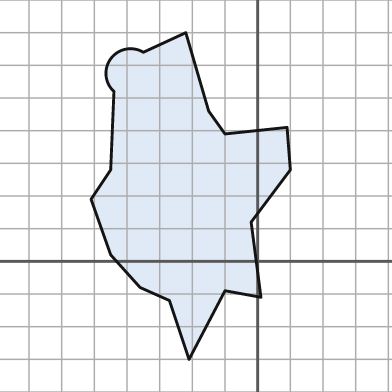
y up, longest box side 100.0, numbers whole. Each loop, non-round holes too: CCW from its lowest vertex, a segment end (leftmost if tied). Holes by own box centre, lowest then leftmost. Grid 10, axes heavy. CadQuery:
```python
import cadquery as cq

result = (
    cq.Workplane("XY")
    .moveTo(-21.0, -30.0)
    .lineTo(-10.0, -9.0)
    .lineTo(1.0, -11.0)
    .lineTo(-2.0, 12.0)
    .lineTo(10.0, 28.0)
    .lineTo(9.0, 41.0)
    .lineTo(-10.0, 39.0)
    .lineTo(-15.0, 46.0)
    .lineTo(-22.0, 70.0)
    .lineTo(-35.0, 64.0)
    .threePointArc((-45.0, 62.0), (-44.0, 52.0))
    .lineTo(-45.0, 28.0)
    .lineTo(-51.0, 19.0)
    .lineTo(-45.0, 2.0)
    .lineTo(-36.0, -8.0)
    .lineTo(-27.0, -12.0)
    .close()
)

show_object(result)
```